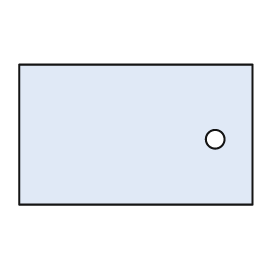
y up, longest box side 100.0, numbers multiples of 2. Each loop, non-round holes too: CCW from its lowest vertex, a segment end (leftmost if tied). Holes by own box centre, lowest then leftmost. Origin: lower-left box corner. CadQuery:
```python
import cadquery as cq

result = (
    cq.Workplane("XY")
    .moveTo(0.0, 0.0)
    .lineTo(100.0, 0.0)
    .lineTo(100.0, 60.0)
    .lineTo(0.0, 60.0)
    .close()
    .moveTo(84.0, 28.0)
    .circle(4.0)
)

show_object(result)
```